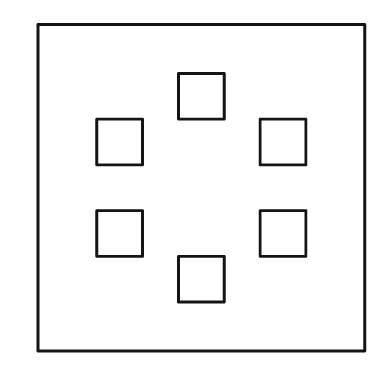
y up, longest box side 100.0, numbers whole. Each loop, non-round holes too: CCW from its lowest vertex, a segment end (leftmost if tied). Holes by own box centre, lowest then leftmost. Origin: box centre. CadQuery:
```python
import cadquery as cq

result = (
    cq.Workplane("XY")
    .moveTo(-50.0, -50.0)
    .lineTo(50.0, -50.0)
    .lineTo(50.0, 50.0)
    .lineTo(-50.0, 50.0)
    .close()
    .moveTo(-7.0, -35.0)
    .lineTo(7.0, -35.0)
    .lineTo(7.0, -21.0)
    .lineTo(-7.0, -21.0)
    .close()
    .moveTo(-32.0, -21.0)
    .lineTo(-18.0, -21.0)
    .lineTo(-18.0, -7.0)
    .lineTo(-32.0, -7.0)
    .close()
    .moveTo(18.0, -21.0)
    .lineTo(32.0, -21.0)
    .lineTo(32.0, -7.0)
    .lineTo(18.0, -7.0)
    .close()
    .moveTo(-32.0, 7.0)
    .lineTo(-18.0, 7.0)
    .lineTo(-18.0, 21.0)
    .lineTo(-32.0, 21.0)
    .close()
    .moveTo(18.0, 7.0)
    .lineTo(32.0, 7.0)
    .lineTo(32.0, 21.0)
    .lineTo(18.0, 21.0)
    .close()
    .moveTo(-7.0, 21.0)
    .lineTo(7.0, 21.0)
    .lineTo(7.0, 35.0)
    .lineTo(-7.0, 35.0)
    .close()
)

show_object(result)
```